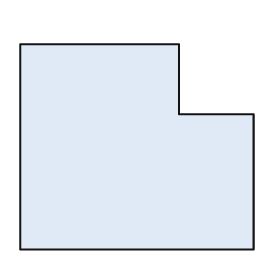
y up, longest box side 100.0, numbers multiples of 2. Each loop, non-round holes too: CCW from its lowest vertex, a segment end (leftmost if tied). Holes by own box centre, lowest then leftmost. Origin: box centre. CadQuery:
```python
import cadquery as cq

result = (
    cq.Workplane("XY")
    .moveTo(-50.0, -44.0)
    .lineTo(50.0, -44.0)
    .lineTo(50.0, 14.0)
    .lineTo(18.0, 14.0)
    .lineTo(18.0, 44.0)
    .lineTo(-50.0, 44.0)
    .close()
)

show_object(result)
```